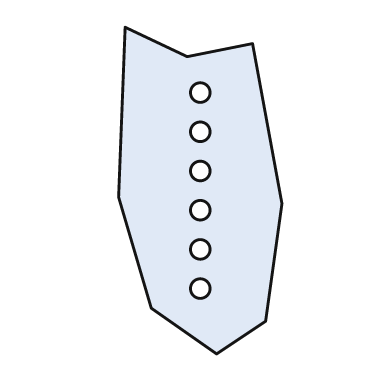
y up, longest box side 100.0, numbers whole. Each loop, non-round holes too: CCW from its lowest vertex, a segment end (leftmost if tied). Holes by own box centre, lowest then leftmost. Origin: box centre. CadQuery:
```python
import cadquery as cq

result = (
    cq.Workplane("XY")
    .moveTo(5.0, -50.0)
    .lineTo(20.0, -40.0)
    .lineTo(25.0, -4.0)
    .lineTo(16.0, 45.0)
    .lineTo(-4.0, 41.0)
    .lineTo(-23.0, 50.0)
    .lineTo(-25.0, -2.0)
    .lineTo(-15.0, -36.0)
    .close()
    .moveTo(0.0, -30.0)
    .circle(3.0)
    .moveTo(0.0, -18.0)
    .circle(3.0)
    .moveTo(0.0, -6.0)
    .circle(3.0)
    .moveTo(0.0, 6.0)
    .circle(3.0)
    .moveTo(0.0, 18.0)
    .circle(3.0)
    .moveTo(0.0, 30.0)
    .circle(3.0)
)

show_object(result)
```